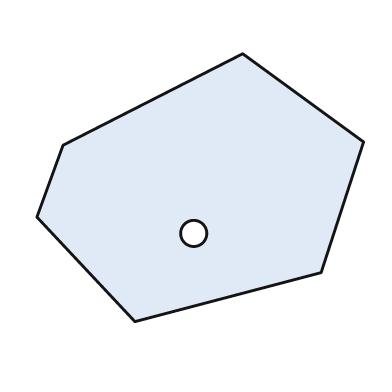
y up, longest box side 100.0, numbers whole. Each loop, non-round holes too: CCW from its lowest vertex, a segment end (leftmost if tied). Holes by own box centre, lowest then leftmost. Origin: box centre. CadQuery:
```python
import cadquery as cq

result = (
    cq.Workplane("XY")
    .moveTo(-20.0, -41.0)
    .lineTo(37.0, -26.0)
    .lineTo(50.0, 14.0)
    .lineTo(13.0, 41.0)
    .lineTo(-42.0, 13.0)
    .lineTo(-50.0, -9.0)
    .close()
    .moveTo(-2.0, -14.0)
    .circle(4.0)
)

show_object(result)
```